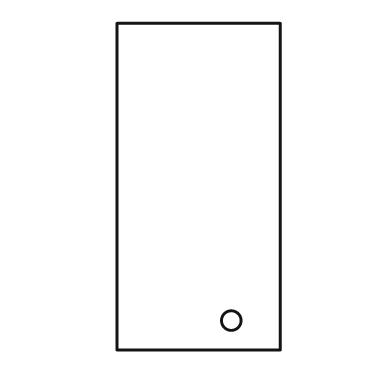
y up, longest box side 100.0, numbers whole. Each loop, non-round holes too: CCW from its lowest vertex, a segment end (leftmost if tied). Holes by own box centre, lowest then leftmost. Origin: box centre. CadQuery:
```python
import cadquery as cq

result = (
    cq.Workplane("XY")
    .moveTo(-25.0, -50.0)
    .lineTo(25.0, -50.0)
    .lineTo(25.0, 50.0)
    .lineTo(-25.0, 50.0)
    .close()
    .moveTo(10.0, -41.0)
    .circle(3.0)
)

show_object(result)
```